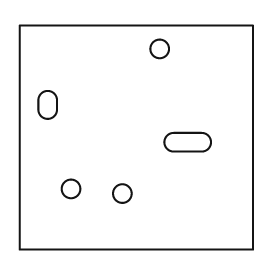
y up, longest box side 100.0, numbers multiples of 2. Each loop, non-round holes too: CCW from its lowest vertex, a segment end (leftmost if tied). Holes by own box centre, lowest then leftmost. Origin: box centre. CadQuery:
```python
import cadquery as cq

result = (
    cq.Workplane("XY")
    .moveTo(-50.0, -48.0)
    .lineTo(50.0, -48.0)
    .lineTo(50.0, 48.0)
    .lineTo(-50.0, 48.0)
    .close()
    .moveTo(-6.0, -24.0)
    .circle(4.0)
    .moveTo(-28.0, -22.0)
    .circle(4.0)
    .moveTo(16.0, -6.0)
    .lineTo(28.0, -6.0)
    .threePointArc((32.0, -2.0), (28.0, 2.0))
    .lineTo(16.0, 2.0)
    .threePointArc((12.0, -2.0), (16.0, -6.0))
    .close()
    .moveTo(-42.0, 12.0)
    .threePointArc((-38.0, 8.0), (-34.0, 12.0))
    .lineTo(-34.0, 16.0)
    .threePointArc((-38.0, 20.0), (-42.0, 16.0))
    .close()
    .moveTo(10.0, 38.0)
    .circle(4.0)
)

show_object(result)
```